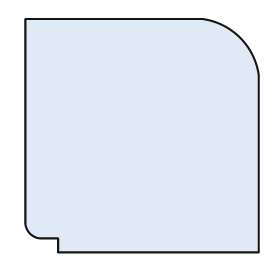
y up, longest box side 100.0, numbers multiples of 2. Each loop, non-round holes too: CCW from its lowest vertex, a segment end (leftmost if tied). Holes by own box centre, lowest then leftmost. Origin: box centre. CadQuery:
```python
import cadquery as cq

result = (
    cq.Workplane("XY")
    .moveTo(-36.0, -50.0)
    .lineTo(50.0, -50.0)
    .lineTo(50.0, 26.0)
    .threePointArc((42.0, 42.0), (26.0, 50.0))
    .lineTo(-50.0, 50.0)
    .lineTo(-50.0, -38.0)
    .threePointArc((-48.0, -42.0), (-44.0, -44.0))
    .lineTo(-36.0, -44.0)
    .close()
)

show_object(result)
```